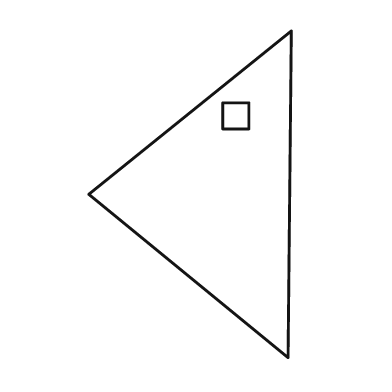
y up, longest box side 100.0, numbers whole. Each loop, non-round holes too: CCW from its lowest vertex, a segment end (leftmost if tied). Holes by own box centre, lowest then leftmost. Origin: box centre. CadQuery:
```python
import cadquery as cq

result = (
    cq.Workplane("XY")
    .moveTo(30.0, -50.0)
    .lineTo(31.0, 50.0)
    .lineTo(-31.0, 0.0)
    .close()
    .moveTo(10.0, 20.0)
    .lineTo(18.0, 20.0)
    .lineTo(18.0, 28.0)
    .lineTo(10.0, 28.0)
    .close()
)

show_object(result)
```